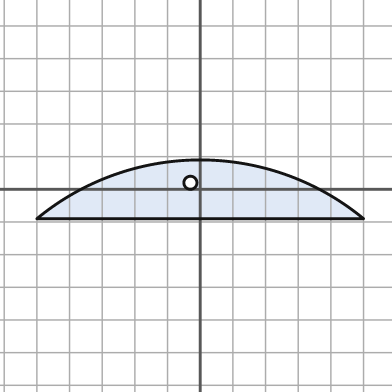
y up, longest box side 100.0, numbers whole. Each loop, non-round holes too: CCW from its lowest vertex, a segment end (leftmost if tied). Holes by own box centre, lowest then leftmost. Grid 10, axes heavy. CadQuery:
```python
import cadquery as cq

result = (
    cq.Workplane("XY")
    .moveTo(-50.0, -9.0)
    .lineTo(50.0, -9.0)
    .threePointArc((0.0, 9.0), (-50.0, -9.0))
    .close()
    .moveTo(-3.0, 2.0)
    .circle(2.0)
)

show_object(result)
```